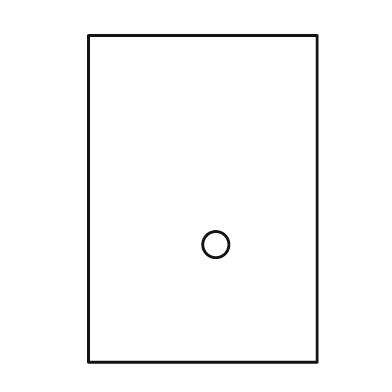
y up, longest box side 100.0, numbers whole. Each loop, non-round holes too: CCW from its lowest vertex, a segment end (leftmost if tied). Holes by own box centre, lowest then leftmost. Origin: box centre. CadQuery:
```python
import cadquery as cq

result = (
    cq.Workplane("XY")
    .moveTo(-35.0, -50.0)
    .lineTo(35.0, -50.0)
    .lineTo(35.0, 50.0)
    .lineTo(-35.0, 50.0)
    .close()
    .moveTo(4.0, -14.0)
    .circle(4.0)
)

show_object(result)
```